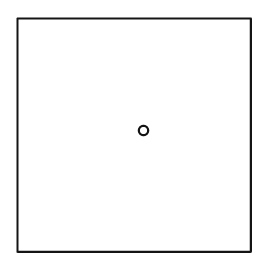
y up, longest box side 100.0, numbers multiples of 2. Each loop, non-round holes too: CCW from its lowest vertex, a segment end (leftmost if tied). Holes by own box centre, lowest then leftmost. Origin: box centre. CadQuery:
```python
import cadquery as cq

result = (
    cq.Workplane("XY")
    .moveTo(-50.0, -50.0)
    .lineTo(50.0, -50.0)
    .lineTo(50.0, 50.0)
    .lineTo(-50.0, 50.0)
    .close()
    .moveTo(4.0, 2.0)
    .circle(2.0)
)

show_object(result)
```